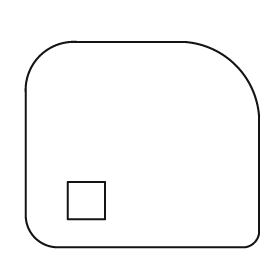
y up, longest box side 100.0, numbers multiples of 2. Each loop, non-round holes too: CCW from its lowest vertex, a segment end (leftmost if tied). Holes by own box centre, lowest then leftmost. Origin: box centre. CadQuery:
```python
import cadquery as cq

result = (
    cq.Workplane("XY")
    .moveTo(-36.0, -44.0)
    .lineTo(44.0, -44.0)
    .threePointArc((48.0, -42.0), (50.0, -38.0))
    .lineTo(50.0, 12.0)
    .threePointArc((40.0, 34.0), (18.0, 44.0))
    .lineTo(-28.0, 44.0)
    .threePointArc((-44.0, 38.0), (-50.0, 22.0))
    .lineTo(-50.0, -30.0)
    .threePointArc((-46.0, -40.0), (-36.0, -44.0))
    .close()
    .moveTo(-32.0, -32.0)
    .lineTo(-16.0, -32.0)
    .lineTo(-16.0, -16.0)
    .lineTo(-32.0, -16.0)
    .close()
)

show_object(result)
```